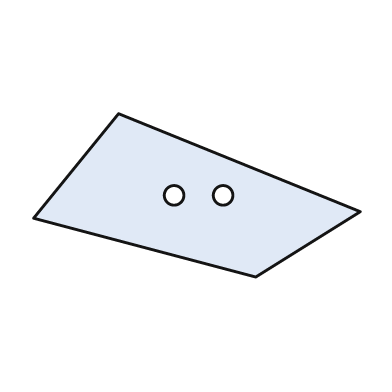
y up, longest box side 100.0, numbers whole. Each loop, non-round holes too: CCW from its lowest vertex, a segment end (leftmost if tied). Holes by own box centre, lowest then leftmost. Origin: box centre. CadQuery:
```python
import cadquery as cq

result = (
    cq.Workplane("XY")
    .moveTo(18.0, -25.0)
    .lineTo(50.0, -5.0)
    .lineTo(-24.0, 25.0)
    .lineTo(-50.0, -7.0)
    .close()
    .moveTo(-7.0, 0.0)
    .circle(3.0)
    .moveTo(8.0, 0.0)
    .circle(3.0)
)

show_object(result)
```